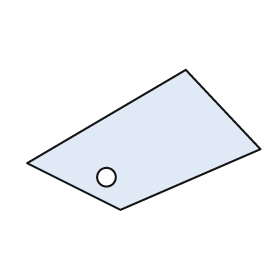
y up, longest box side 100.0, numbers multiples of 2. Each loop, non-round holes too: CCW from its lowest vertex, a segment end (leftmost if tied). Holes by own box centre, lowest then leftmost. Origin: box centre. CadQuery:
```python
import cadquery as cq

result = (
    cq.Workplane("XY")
    .moveTo(-10.0, -30.0)
    .lineTo(50.0, -4.0)
    .lineTo(18.0, 30.0)
    .lineTo(-50.0, -10.0)
    .close()
    .moveTo(-16.0, -16.0)
    .circle(4.0)
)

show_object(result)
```